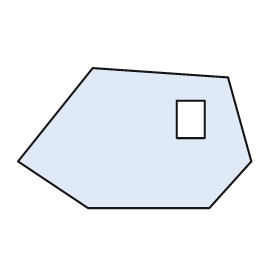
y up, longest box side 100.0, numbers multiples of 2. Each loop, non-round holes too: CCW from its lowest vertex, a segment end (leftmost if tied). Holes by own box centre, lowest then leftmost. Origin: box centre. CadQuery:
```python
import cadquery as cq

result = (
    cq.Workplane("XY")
    .moveTo(-20.0, -30.0)
    .lineTo(32.0, -30.0)
    .lineTo(50.0, -10.0)
    .lineTo(40.0, 26.0)
    .lineTo(-18.0, 30.0)
    .lineTo(-50.0, -10.0)
    .close()
    .moveTo(18.0, 0.0)
    .lineTo(30.0, 0.0)
    .lineTo(30.0, 16.0)
    .lineTo(18.0, 16.0)
    .close()
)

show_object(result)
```